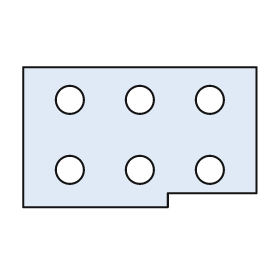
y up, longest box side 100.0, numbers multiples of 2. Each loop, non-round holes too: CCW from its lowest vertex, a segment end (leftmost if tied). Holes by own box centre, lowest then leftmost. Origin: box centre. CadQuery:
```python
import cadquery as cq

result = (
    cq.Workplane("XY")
    .moveTo(-50.0, -30.0)
    .lineTo(12.0, -30.0)
    .lineTo(12.0, -24.0)
    .lineTo(50.0, -24.0)
    .lineTo(50.0, 30.0)
    .lineTo(-50.0, 30.0)
    .close()
    .moveTo(-30.0, -14.0)
    .circle(6.0)
    .moveTo(0.0, -14.0)
    .circle(6.0)
    .moveTo(30.0, -14.0)
    .circle(6.0)
    .moveTo(-30.0, 16.0)
    .circle(6.0)
    .moveTo(0.0, 16.0)
    .circle(6.0)
    .moveTo(30.0, 16.0)
    .circle(6.0)
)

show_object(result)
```